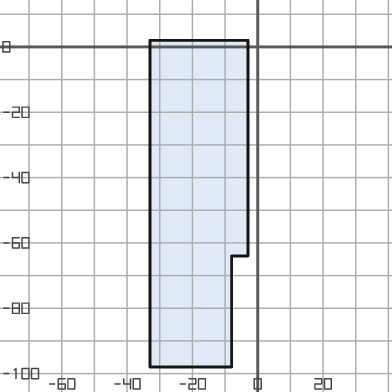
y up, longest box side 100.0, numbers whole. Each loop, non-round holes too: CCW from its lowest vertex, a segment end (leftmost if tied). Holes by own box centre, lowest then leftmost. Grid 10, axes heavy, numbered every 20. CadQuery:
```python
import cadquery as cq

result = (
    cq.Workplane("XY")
    .moveTo(-33.0, -98.0)
    .lineTo(-8.0, -98.0)
    .lineTo(-8.0, -64.0)
    .lineTo(-3.0, -64.0)
    .lineTo(-3.0, 2.0)
    .lineTo(-33.0, 2.0)
    .close()
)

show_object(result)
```